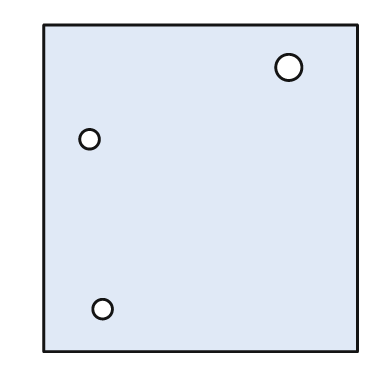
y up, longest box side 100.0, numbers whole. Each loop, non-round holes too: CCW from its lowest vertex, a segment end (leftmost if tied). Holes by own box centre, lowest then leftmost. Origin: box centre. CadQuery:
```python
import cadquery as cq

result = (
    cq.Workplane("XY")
    .moveTo(-48.0, -50.0)
    .lineTo(48.0, -50.0)
    .lineTo(48.0, 50.0)
    .lineTo(-48.0, 50.0)
    .close()
    .moveTo(-30.0, -37.0)
    .circle(3.0)
    .moveTo(-34.0, 15.0)
    .circle(3.0)
    .moveTo(27.0, 37.0)
    .circle(4.0)
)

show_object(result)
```